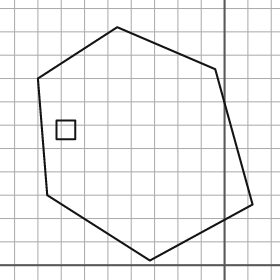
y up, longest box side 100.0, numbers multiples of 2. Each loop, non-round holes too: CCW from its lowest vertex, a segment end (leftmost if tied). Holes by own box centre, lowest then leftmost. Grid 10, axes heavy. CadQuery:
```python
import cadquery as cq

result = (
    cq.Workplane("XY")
    .moveTo(-32.0, 2.0)
    .lineTo(12.0, 26.0)
    .lineTo(-4.0, 84.0)
    .lineTo(-46.0, 102.0)
    .lineTo(-80.0, 80.0)
    .lineTo(-76.0, 30.0)
    .close()
    .moveTo(-72.0, 54.0)
    .lineTo(-64.0, 54.0)
    .lineTo(-64.0, 62.0)
    .lineTo(-72.0, 62.0)
    .close()
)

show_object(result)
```